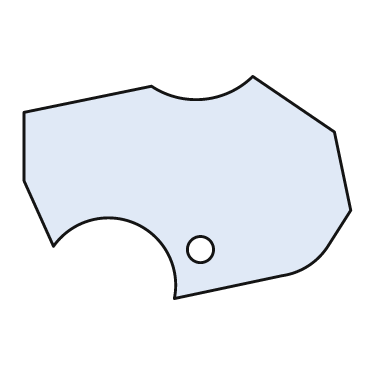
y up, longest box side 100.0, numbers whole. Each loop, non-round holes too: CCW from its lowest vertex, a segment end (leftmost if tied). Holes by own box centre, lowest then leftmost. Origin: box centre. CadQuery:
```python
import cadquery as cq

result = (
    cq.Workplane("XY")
    .moveTo(-4.0, -34.0)
    .lineTo(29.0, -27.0)
    .threePointArc((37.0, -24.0), (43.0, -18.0))
    .lineTo(50.0, -7.0)
    .lineTo(45.0, 17.0)
    .lineTo(20.0, 34.0)
    .threePointArc((5.0, 27.0), (-11.0, 31.0))
    .lineTo(-50.0, 23.0)
    .lineTo(-50.0, 2.0)
    .lineTo(-41.0, -18.0)
    .threePointArc((-16.0, -11.0), (-4.0, -34.0))
    .close()
    .moveTo(4.0, -19.0)
    .circle(4.0)
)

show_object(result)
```